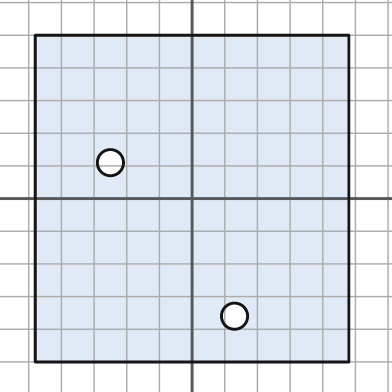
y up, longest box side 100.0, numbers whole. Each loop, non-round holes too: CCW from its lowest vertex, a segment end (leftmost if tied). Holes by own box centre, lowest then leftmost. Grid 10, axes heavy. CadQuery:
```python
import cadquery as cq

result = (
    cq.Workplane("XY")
    .moveTo(-48.0, -50.0)
    .lineTo(48.0, -50.0)
    .lineTo(48.0, 50.0)
    .lineTo(-48.0, 50.0)
    .close()
    .moveTo(13.0, -36.0)
    .circle(4.0)
    .moveTo(-25.0, 11.0)
    .circle(4.0)
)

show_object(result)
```